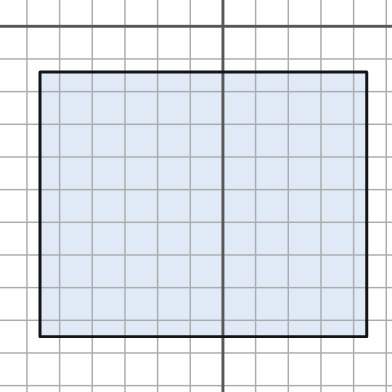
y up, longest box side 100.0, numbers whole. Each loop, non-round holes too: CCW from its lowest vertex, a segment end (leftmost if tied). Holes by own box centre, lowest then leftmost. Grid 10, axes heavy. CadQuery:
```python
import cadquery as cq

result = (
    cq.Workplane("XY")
    .moveTo(-56.0, -95.0)
    .lineTo(44.0, -95.0)
    .lineTo(44.0, -14.0)
    .lineTo(-56.0, -14.0)
    .close()
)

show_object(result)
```